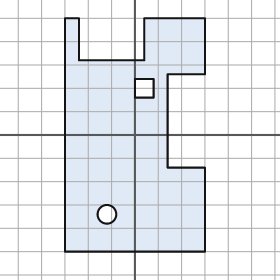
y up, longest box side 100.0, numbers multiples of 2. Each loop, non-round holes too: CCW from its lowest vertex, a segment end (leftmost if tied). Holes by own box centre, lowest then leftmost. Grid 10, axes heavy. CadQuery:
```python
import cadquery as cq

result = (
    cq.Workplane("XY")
    .moveTo(-30.0, -50.0)
    .lineTo(30.0, -50.0)
    .lineTo(30.0, -14.0)
    .lineTo(14.0, -14.0)
    .lineTo(14.0, 26.0)
    .lineTo(30.0, 26.0)
    .lineTo(30.0, 50.0)
    .lineTo(4.0, 50.0)
    .lineTo(4.0, 32.0)
    .lineTo(-24.0, 32.0)
    .lineTo(-24.0, 50.0)
    .lineTo(-30.0, 50.0)
    .close()
    .moveTo(-12.0, -34.0)
    .circle(4.0)
    .moveTo(0.0, 16.0)
    .lineTo(8.0, 16.0)
    .lineTo(8.0, 24.0)
    .lineTo(0.0, 24.0)
    .close()
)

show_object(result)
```